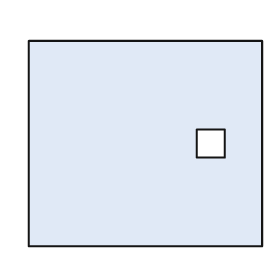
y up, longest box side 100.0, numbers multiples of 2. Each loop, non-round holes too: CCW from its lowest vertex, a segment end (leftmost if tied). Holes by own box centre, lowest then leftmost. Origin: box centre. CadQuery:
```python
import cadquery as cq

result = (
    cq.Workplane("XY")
    .moveTo(-50.0, -44.0)
    .lineTo(50.0, -44.0)
    .lineTo(50.0, 44.0)
    .lineTo(-50.0, 44.0)
    .close()
    .moveTo(22.0, -6.0)
    .lineTo(34.0, -6.0)
    .lineTo(34.0, 6.0)
    .lineTo(22.0, 6.0)
    .close()
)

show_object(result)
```